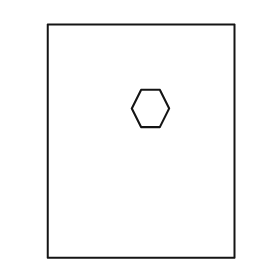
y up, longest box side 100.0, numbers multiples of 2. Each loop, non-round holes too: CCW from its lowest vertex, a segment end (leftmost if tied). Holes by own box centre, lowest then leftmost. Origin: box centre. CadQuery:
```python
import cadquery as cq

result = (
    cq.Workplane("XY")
    .moveTo(-40.0, -50.0)
    .lineTo(40.0, -50.0)
    .lineTo(40.0, 50.0)
    .lineTo(-40.0, 50.0)
    .close()
    .moveTo(0.0, 6.0)
    .lineTo(8.0, 6.0)
    .lineTo(12.0, 14.0)
    .lineTo(8.0, 22.0)
    .lineTo(0.0, 22.0)
    .lineTo(-4.0, 14.0)
    .close()
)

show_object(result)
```